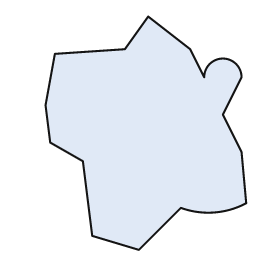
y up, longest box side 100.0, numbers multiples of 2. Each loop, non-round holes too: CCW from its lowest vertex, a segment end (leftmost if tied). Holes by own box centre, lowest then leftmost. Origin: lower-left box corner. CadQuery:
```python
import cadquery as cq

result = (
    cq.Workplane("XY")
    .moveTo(40.0, 0.0)
    .lineTo(58.0, 18.0)
    .threePointArc((72.0, 16.0), (86.0, 20.0))
    .lineTo(84.0, 42.0)
    .lineTo(76.0, 58.0)
    .lineTo(84.0, 74.0)
    .threePointArc((76.0, 82.0), (68.0, 74.0))
    .lineTo(62.0, 86.0)
    .lineTo(44.0, 100.0)
    .lineTo(34.0, 86.0)
    .lineTo(4.0, 84.0)
    .lineTo(0.0, 62.0)
    .lineTo(2.0, 46.0)
    .lineTo(16.0, 38.0)
    .lineTo(20.0, 6.0)
    .close()
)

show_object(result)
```